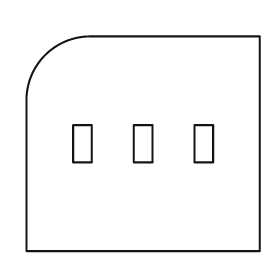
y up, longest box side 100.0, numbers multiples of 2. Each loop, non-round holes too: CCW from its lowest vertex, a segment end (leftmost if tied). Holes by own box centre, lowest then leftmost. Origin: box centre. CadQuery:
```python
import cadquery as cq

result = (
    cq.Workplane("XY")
    .moveTo(-50.0, -46.0)
    .lineTo(50.0, -46.0)
    .lineTo(50.0, 46.0)
    .lineTo(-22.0, 46.0)
    .threePointArc((-42.0, 38.0), (-50.0, 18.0))
    .close()
    .moveTo(-30.0, -8.0)
    .lineTo(-22.0, -8.0)
    .lineTo(-22.0, 8.0)
    .lineTo(-30.0, 8.0)
    .close()
    .moveTo(-4.0, -8.0)
    .lineTo(4.0, -8.0)
    .lineTo(4.0, 8.0)
    .lineTo(-4.0, 8.0)
    .close()
    .moveTo(22.0, -8.0)
    .lineTo(30.0, -8.0)
    .lineTo(30.0, 8.0)
    .lineTo(22.0, 8.0)
    .close()
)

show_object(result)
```